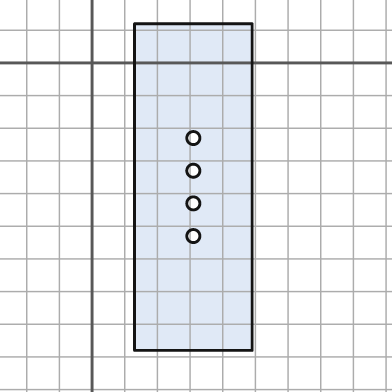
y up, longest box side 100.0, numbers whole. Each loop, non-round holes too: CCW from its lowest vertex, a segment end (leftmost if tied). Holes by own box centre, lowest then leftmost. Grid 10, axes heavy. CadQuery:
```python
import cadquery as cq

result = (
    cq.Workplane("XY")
    .moveTo(13.0, -88.0)
    .lineTo(49.0, -88.0)
    .lineTo(49.0, 12.0)
    .lineTo(13.0, 12.0)
    .close()
    .moveTo(31.0, -53.0)
    .circle(2.0)
    .moveTo(31.0, -43.0)
    .circle(2.0)
    .moveTo(31.0, -33.0)
    .circle(2.0)
    .moveTo(31.0, -23.0)
    .circle(2.0)
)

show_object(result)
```